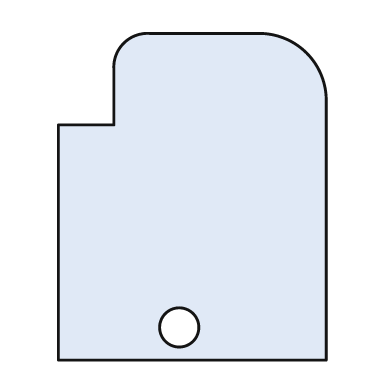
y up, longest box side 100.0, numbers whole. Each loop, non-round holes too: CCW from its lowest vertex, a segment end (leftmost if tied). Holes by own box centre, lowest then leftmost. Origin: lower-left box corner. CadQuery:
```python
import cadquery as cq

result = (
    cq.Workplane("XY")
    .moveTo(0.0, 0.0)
    .lineTo(82.0, 0.0)
    .lineTo(82.0, 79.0)
    .threePointArc((76.0, 94.0), (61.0, 100.0))
    .lineTo(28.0, 100.0)
    .threePointArc((20.0, 97.0), (17.0, 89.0))
    .lineTo(17.0, 72.0)
    .lineTo(0.0, 72.0)
    .close()
    .moveTo(37.0, 10.0)
    .circle(6.0)
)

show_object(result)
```